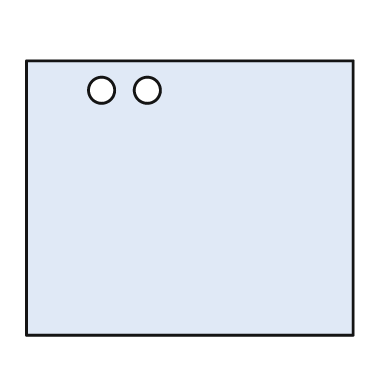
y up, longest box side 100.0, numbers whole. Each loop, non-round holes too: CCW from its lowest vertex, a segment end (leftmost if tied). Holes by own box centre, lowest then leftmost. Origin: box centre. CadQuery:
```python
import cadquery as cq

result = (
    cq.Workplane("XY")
    .moveTo(-50.0, -42.0)
    .lineTo(50.0, -42.0)
    .lineTo(50.0, 42.0)
    .lineTo(-50.0, 42.0)
    .close()
    .moveTo(-27.0, 33.0)
    .circle(4.0)
    .moveTo(-13.0, 33.0)
    .circle(4.0)
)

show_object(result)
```